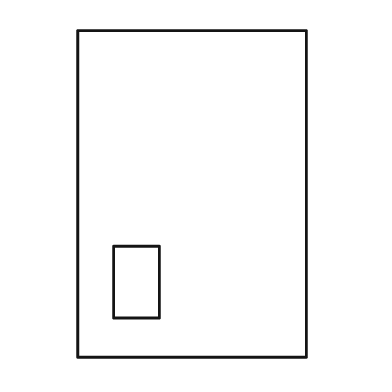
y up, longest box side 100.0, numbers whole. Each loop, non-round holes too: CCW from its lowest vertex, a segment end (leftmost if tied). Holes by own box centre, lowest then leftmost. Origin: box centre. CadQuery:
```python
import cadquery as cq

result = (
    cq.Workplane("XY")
    .moveTo(-35.0, -50.0)
    .lineTo(35.0, -50.0)
    .lineTo(35.0, 50.0)
    .lineTo(-35.0, 50.0)
    .close()
    .moveTo(-24.0, -38.0)
    .lineTo(-10.0, -38.0)
    .lineTo(-10.0, -16.0)
    .lineTo(-24.0, -16.0)
    .close()
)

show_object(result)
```